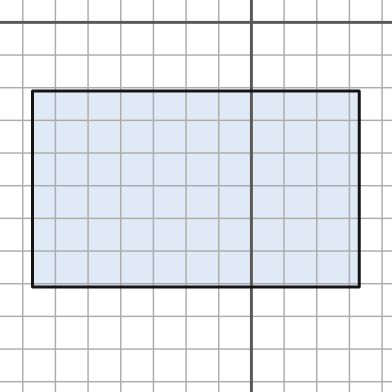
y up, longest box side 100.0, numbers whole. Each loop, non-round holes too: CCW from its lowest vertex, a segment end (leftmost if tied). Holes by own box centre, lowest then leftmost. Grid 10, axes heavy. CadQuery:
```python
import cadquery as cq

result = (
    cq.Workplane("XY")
    .moveTo(-67.0, -81.0)
    .lineTo(33.0, -81.0)
    .lineTo(33.0, -21.0)
    .lineTo(-67.0, -21.0)
    .close()
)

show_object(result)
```